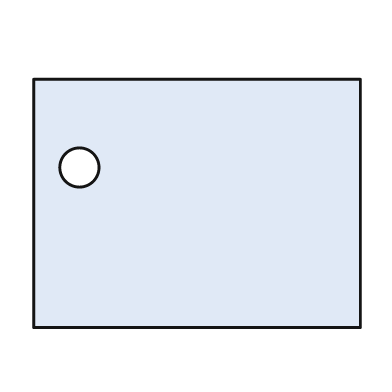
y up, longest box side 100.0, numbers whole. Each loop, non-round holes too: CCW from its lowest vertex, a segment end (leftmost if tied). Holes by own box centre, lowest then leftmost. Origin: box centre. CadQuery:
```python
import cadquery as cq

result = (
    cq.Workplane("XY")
    .moveTo(-50.0, -38.0)
    .lineTo(50.0, -38.0)
    .lineTo(50.0, 38.0)
    .lineTo(-50.0, 38.0)
    .close()
    .moveTo(-36.0, 11.0)
    .circle(6.0)
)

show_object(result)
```